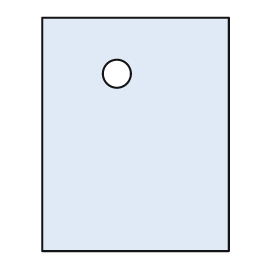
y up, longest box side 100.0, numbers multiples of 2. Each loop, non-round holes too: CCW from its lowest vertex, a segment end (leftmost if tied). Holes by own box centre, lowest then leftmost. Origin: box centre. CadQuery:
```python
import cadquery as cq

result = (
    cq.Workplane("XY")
    .moveTo(-40.0, -50.0)
    .lineTo(40.0, -50.0)
    .lineTo(40.0, 50.0)
    .lineTo(-40.0, 50.0)
    .close()
    .moveTo(-8.0, 26.0)
    .circle(6.0)
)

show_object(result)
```